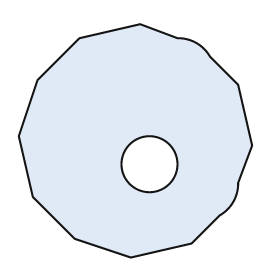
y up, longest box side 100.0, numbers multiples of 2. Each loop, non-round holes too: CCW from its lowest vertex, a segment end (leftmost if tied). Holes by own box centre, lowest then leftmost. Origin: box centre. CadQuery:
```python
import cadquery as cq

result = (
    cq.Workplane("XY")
    .moveTo(-2.0, -50.0)
    .lineTo(24.0, -44.0)
    .lineTo(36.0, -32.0)
    .threePointArc((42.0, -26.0), (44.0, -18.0))
    .lineTo(50.0, -2.0)
    .lineTo(44.0, 24.0)
    .lineTo(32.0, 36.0)
    .threePointArc((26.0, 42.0), (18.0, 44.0))
    .lineTo(2.0, 50.0)
    .lineTo(-24.0, 44.0)
    .lineTo(-42.0, 26.0)
    .lineTo(-50.0, 2.0)
    .lineTo(-44.0, -24.0)
    .lineTo(-26.0, -42.0)
    .close()
    .moveTo(6.0, -10.0)
    .circle(12.0)
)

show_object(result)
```